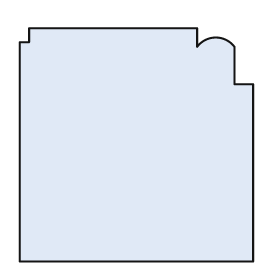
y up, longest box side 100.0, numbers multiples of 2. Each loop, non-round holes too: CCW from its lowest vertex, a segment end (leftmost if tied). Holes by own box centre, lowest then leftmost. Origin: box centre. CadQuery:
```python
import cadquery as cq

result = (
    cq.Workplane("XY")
    .moveTo(-50.0, -50.0)
    .lineTo(50.0, -50.0)
    .lineTo(50.0, 26.0)
    .lineTo(42.0, 26.0)
    .lineTo(42.0, 42.0)
    .threePointArc((34.0, 46.0), (26.0, 42.0))
    .lineTo(26.0, 50.0)
    .lineTo(-46.0, 50.0)
    .lineTo(-46.0, 44.0)
    .lineTo(-50.0, 44.0)
    .close()
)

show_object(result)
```